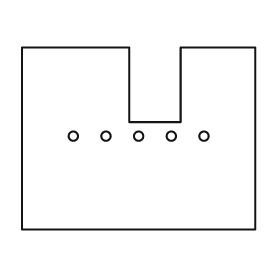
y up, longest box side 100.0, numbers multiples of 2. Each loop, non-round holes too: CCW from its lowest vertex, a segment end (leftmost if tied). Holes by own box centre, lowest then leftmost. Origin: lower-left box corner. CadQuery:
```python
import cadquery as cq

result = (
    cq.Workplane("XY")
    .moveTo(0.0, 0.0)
    .lineTo(100.0, 0.0)
    .lineTo(100.0, 78.0)
    .lineTo(68.0, 78.0)
    .lineTo(68.0, 46.0)
    .lineTo(46.0, 46.0)
    .lineTo(46.0, 78.0)
    .lineTo(0.0, 78.0)
    .close()
    .moveTo(22.0, 40.0)
    .circle(2.0)
    .moveTo(36.0, 40.0)
    .circle(2.0)
    .moveTo(50.0, 40.0)
    .circle(2.0)
    .moveTo(64.0, 40.0)
    .circle(2.0)
    .moveTo(78.0, 40.0)
    .circle(2.0)
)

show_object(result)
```